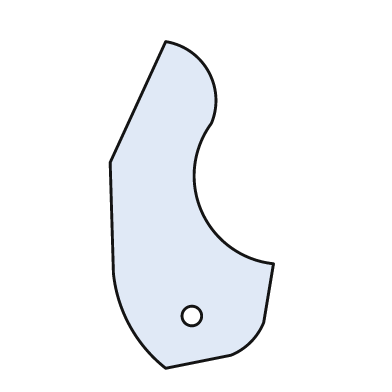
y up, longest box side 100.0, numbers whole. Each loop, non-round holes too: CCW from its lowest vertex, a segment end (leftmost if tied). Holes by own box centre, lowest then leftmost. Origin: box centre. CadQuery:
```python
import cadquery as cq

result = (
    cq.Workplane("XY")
    .moveTo(-8.0, -50.0)
    .lineTo(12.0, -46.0)
    .threePointArc((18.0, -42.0), (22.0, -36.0))
    .lineTo(25.0, -18.0)
    .threePointArc((3.0, -2.0), (6.0, 25.0))
    .threePointArc((5.0, 41.0), (-8.0, 50.0))
    .lineTo(-25.0, 13.0)
    .lineTo(-24.0, -21.0)
    .threePointArc((-19.0, -37.0), (-8.0, -50.0))
    .close()
    .moveTo(0.0, -34.0)
    .circle(3.0)
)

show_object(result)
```